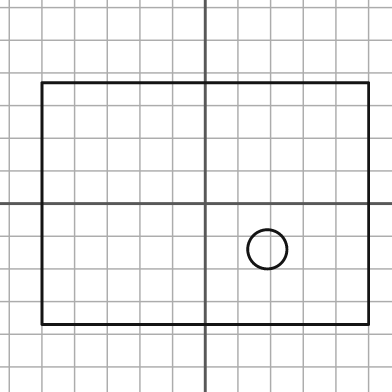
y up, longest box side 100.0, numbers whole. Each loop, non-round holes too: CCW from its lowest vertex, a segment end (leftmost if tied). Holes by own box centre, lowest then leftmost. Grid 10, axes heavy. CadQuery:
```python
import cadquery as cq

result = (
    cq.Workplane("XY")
    .moveTo(-50.0, -37.0)
    .lineTo(50.0, -37.0)
    .lineTo(50.0, 37.0)
    .lineTo(-50.0, 37.0)
    .close()
    .moveTo(19.0, -14.0)
    .circle(6.0)
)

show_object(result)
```